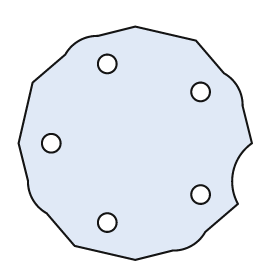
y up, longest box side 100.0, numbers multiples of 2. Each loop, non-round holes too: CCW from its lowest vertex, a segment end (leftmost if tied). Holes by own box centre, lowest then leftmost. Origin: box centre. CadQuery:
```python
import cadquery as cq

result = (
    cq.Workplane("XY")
    .moveTo(0.0, -50.0)
    .lineTo(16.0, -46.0)
    .threePointArc((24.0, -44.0), (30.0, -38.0))
    .lineTo(44.0, -26.0)
    .threePointArc((42.0, -12.0), (50.0, 0.0))
    .lineTo(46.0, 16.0)
    .threePointArc((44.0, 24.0), (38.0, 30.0))
    .lineTo(26.0, 44.0)
    .lineTo(0.0, 50.0)
    .lineTo(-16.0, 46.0)
    .threePointArc((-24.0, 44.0), (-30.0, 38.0))
    .lineTo(-44.0, 26.0)
    .lineTo(-50.0, 0.0)
    .lineTo(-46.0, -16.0)
    .threePointArc((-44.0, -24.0), (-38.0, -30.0))
    .lineTo(-26.0, -44.0)
    .close()
    .moveTo(-12.0, -34.0)
    .circle(4.0)
    .moveTo(28.0, -22.0)
    .circle(4.0)
    .moveTo(-36.0, 0.0)
    .circle(4.0)
    .moveTo(28.0, 22.0)
    .circle(4.0)
    .moveTo(-12.0, 34.0)
    .circle(4.0)
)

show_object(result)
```